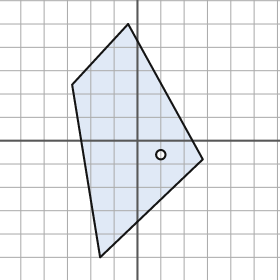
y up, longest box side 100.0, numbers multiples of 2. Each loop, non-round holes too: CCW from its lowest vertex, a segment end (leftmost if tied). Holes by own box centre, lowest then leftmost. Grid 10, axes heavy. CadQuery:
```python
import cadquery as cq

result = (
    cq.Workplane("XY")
    .moveTo(-16.0, -50.0)
    .lineTo(28.0, -8.0)
    .lineTo(-4.0, 50.0)
    .lineTo(-28.0, 24.0)
    .close()
    .moveTo(10.0, -6.0)
    .circle(2.0)
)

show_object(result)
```